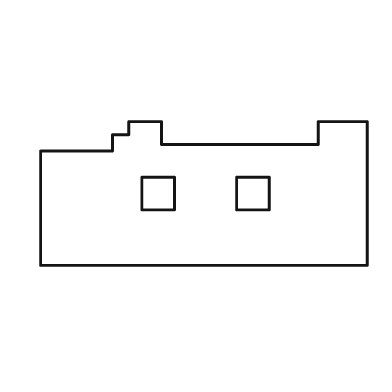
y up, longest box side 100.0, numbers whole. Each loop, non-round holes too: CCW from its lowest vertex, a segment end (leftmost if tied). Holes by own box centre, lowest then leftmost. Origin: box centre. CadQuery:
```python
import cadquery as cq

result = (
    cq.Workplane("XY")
    .moveTo(-50.0, -22.0)
    .lineTo(50.0, -22.0)
    .lineTo(50.0, 22.0)
    .lineTo(35.0, 22.0)
    .lineTo(35.0, 15.0)
    .lineTo(-13.0, 15.0)
    .lineTo(-13.0, 22.0)
    .lineTo(-23.0, 22.0)
    .lineTo(-23.0, 18.0)
    .lineTo(-28.0, 18.0)
    .lineTo(-28.0, 13.0)
    .lineTo(-50.0, 13.0)
    .close()
    .moveTo(-19.0, -5.0)
    .lineTo(-9.0, -5.0)
    .lineTo(-9.0, 5.0)
    .lineTo(-19.0, 5.0)
    .close()
    .moveTo(10.0, -5.0)
    .lineTo(20.0, -5.0)
    .lineTo(20.0, 5.0)
    .lineTo(10.0, 5.0)
    .close()
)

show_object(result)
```